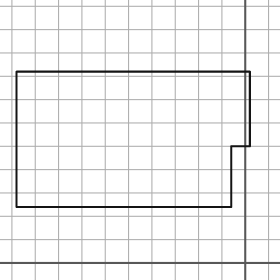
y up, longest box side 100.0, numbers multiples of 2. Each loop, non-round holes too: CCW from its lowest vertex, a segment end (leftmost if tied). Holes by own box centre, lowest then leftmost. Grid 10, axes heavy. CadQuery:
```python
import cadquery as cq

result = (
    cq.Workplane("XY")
    .moveTo(-98.0, 24.0)
    .lineTo(-6.0, 24.0)
    .lineTo(-6.0, 50.0)
    .lineTo(2.0, 50.0)
    .lineTo(2.0, 82.0)
    .lineTo(-98.0, 82.0)
    .close()
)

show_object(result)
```